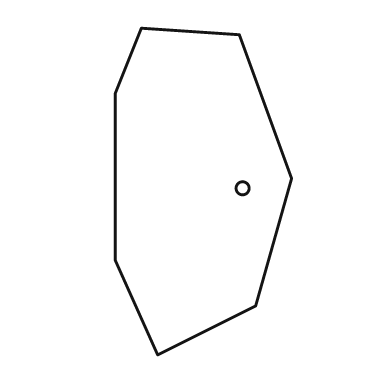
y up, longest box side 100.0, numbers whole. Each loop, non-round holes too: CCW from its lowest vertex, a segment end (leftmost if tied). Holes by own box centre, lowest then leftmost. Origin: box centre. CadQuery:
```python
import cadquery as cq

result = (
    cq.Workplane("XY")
    .moveTo(-14.0, -50.0)
    .lineTo(16.0, -35.0)
    .lineTo(27.0, 4.0)
    .lineTo(11.0, 48.0)
    .lineTo(-19.0, 50.0)
    .lineTo(-27.0, 30.0)
    .lineTo(-27.0, -21.0)
    .close()
    .moveTo(12.0, 1.0)
    .circle(2.0)
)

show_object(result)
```